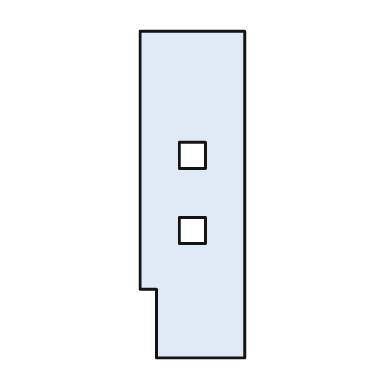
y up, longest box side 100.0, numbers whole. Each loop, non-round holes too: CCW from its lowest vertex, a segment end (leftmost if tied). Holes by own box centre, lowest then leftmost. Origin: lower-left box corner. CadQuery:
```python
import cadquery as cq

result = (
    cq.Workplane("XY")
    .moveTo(5.0, 0.0)
    .lineTo(32.0, 0.0)
    .lineTo(32.0, 100.0)
    .lineTo(0.0, 100.0)
    .lineTo(0.0, 21.0)
    .lineTo(5.0, 21.0)
    .close()
    .moveTo(12.0, 35.0)
    .lineTo(20.0, 35.0)
    .lineTo(20.0, 43.0)
    .lineTo(12.0, 43.0)
    .close()
    .moveTo(12.0, 58.0)
    .lineTo(20.0, 58.0)
    .lineTo(20.0, 66.0)
    .lineTo(12.0, 66.0)
    .close()
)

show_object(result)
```